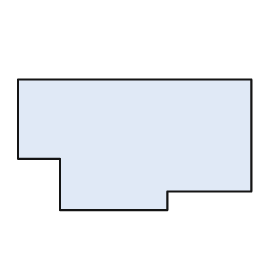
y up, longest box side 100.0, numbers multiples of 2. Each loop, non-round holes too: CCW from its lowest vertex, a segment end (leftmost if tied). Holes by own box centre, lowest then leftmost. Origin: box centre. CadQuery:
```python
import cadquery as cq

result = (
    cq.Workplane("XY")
    .moveTo(-32.0, -28.0)
    .lineTo(14.0, -28.0)
    .lineTo(14.0, -20.0)
    .lineTo(50.0, -20.0)
    .lineTo(50.0, 28.0)
    .lineTo(-50.0, 28.0)
    .lineTo(-50.0, -6.0)
    .lineTo(-32.0, -6.0)
    .close()
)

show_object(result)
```